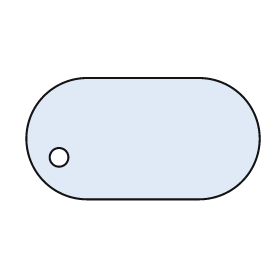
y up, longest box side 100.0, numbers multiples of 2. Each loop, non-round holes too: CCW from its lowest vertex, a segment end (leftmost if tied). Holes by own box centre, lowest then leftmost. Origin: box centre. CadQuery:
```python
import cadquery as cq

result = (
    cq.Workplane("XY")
    .moveTo(-24.0, -26.0)
    .lineTo(24.0, -26.0)
    .threePointArc((50.0, 0.0), (24.0, 26.0))
    .lineTo(-24.0, 26.0)
    .threePointArc((-50.0, 0.0), (-24.0, -26.0))
    .close()
    .moveTo(-36.0, -8.0)
    .circle(4.0)
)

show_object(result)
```